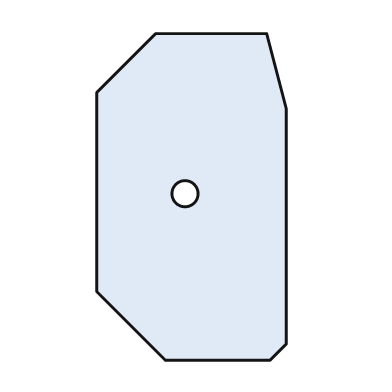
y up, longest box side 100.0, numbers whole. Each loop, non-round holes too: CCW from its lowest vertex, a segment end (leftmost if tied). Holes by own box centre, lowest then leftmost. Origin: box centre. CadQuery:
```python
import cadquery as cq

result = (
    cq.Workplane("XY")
    .moveTo(-8.0, -50.0)
    .lineTo(24.0, -50.0)
    .lineTo(29.0, -45.0)
    .lineTo(29.0, 27.0)
    .lineTo(23.0, 50.0)
    .lineTo(-11.0, 50.0)
    .lineTo(-29.0, 32.0)
    .lineTo(-29.0, -29.0)
    .close()
    .moveTo(-2.0, 1.0)
    .circle(4.0)
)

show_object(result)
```